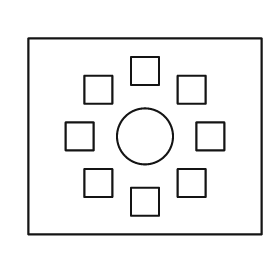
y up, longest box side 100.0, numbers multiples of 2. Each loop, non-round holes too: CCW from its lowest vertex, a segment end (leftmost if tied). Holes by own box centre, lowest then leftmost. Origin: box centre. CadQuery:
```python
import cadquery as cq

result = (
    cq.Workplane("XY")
    .moveTo(-50.0, -42.0)
    .lineTo(50.0, -42.0)
    .lineTo(50.0, 42.0)
    .lineTo(-50.0, 42.0)
    .close()
    .moveTo(-6.0, -34.0)
    .lineTo(6.0, -34.0)
    .lineTo(6.0, -22.0)
    .lineTo(-6.0, -22.0)
    .close()
    .moveTo(-26.0, -26.0)
    .lineTo(-14.0, -26.0)
    .lineTo(-14.0, -14.0)
    .lineTo(-26.0, -14.0)
    .close()
    .moveTo(14.0, -26.0)
    .lineTo(26.0, -26.0)
    .lineTo(26.0, -14.0)
    .lineTo(14.0, -14.0)
    .close()
    .moveTo(-34.0, -6.0)
    .lineTo(-22.0, -6.0)
    .lineTo(-22.0, 6.0)
    .lineTo(-34.0, 6.0)
    .close()
    .moveTo(0.0, 0.0)
    .circle(12.0)
    .moveTo(22.0, -6.0)
    .lineTo(34.0, -6.0)
    .lineTo(34.0, 6.0)
    .lineTo(22.0, 6.0)
    .close()
    .moveTo(-26.0, 14.0)
    .lineTo(-14.0, 14.0)
    .lineTo(-14.0, 26.0)
    .lineTo(-26.0, 26.0)
    .close()
    .moveTo(14.0, 14.0)
    .lineTo(26.0, 14.0)
    .lineTo(26.0, 26.0)
    .lineTo(14.0, 26.0)
    .close()
    .moveTo(-6.0, 22.0)
    .lineTo(6.0, 22.0)
    .lineTo(6.0, 34.0)
    .lineTo(-6.0, 34.0)
    .close()
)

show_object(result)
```